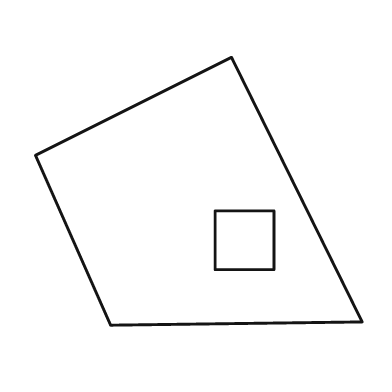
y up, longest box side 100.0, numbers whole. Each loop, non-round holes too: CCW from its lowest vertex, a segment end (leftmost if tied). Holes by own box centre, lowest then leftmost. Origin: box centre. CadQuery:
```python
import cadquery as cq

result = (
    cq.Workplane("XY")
    .moveTo(-27.0, -41.0)
    .lineTo(50.0, -40.0)
    .lineTo(10.0, 41.0)
    .lineTo(-50.0, 11.0)
    .close()
    .moveTo(5.0, -24.0)
    .lineTo(23.0, -24.0)
    .lineTo(23.0, -6.0)
    .lineTo(5.0, -6.0)
    .close()
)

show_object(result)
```